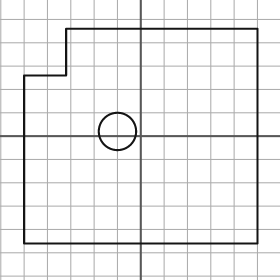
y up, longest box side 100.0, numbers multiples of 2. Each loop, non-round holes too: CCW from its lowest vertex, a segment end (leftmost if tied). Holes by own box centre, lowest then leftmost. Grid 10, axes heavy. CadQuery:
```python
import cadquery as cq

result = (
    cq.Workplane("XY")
    .moveTo(-50.0, -46.0)
    .lineTo(50.0, -46.0)
    .lineTo(50.0, 46.0)
    .lineTo(-32.0, 46.0)
    .lineTo(-32.0, 26.0)
    .lineTo(-50.0, 26.0)
    .close()
    .moveTo(-10.0, 2.0)
    .circle(8.0)
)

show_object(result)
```